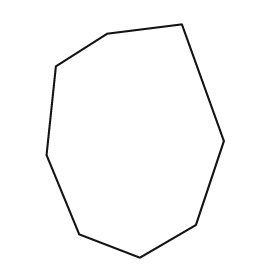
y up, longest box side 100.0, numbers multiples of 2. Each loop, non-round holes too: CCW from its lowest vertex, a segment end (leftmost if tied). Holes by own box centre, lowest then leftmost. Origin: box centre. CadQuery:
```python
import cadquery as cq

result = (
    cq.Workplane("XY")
    .moveTo(2.0, -50.0)
    .lineTo(26.0, -36.0)
    .lineTo(38.0, 0.0)
    .lineTo(20.0, 50.0)
    .lineTo(-12.0, 46.0)
    .lineTo(-34.0, 32.0)
    .lineTo(-38.0, -6.0)
    .lineTo(-24.0, -40.0)
    .close()
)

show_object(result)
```